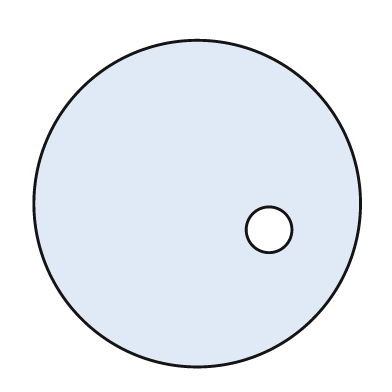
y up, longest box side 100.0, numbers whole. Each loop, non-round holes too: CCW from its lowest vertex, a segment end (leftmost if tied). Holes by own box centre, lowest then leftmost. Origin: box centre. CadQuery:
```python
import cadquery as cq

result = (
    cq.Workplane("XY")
    .moveTo(0.0, 0.0)
    .circle(50.0)
    .moveTo(22.0, -8.0)
    .circle(7.0)
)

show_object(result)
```